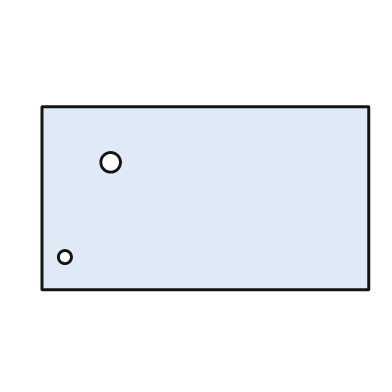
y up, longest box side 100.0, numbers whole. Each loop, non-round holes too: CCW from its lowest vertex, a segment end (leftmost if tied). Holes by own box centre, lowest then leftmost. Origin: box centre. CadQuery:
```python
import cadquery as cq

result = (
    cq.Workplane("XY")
    .moveTo(-50.0, -28.0)
    .lineTo(50.0, -28.0)
    .lineTo(50.0, 28.0)
    .lineTo(-50.0, 28.0)
    .close()
    .moveTo(-43.0, -18.0)
    .circle(2.0)
    .moveTo(-29.0, 11.0)
    .circle(3.0)
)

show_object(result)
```